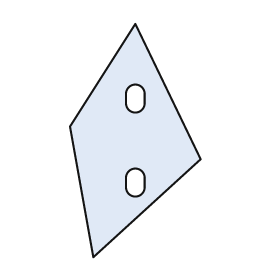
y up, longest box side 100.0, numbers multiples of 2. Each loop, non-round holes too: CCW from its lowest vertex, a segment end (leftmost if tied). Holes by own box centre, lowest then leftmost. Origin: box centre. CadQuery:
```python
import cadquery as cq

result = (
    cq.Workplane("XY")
    .moveTo(-18.0, -50.0)
    .lineTo(28.0, -8.0)
    .lineTo(0.0, 50.0)
    .lineTo(-28.0, 6.0)
    .close()
    .moveTo(-4.0, -20.0)
    .threePointArc((0.0, -24.0), (4.0, -20.0))
    .lineTo(4.0, -16.0)
    .threePointArc((0.0, -12.0), (-4.0, -16.0))
    .close()
    .moveTo(-4.0, 16.0)
    .threePointArc((0.0, 12.0), (4.0, 16.0))
    .lineTo(4.0, 20.0)
    .threePointArc((0.0, 24.0), (-4.0, 20.0))
    .close()
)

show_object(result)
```